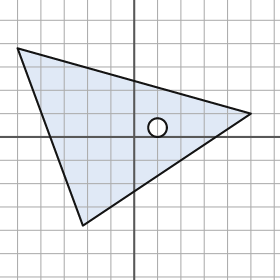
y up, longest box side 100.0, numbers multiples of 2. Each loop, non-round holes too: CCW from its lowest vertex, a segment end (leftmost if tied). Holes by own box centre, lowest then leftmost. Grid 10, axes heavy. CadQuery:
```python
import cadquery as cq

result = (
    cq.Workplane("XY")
    .moveTo(-22.0, -38.0)
    .lineTo(50.0, 10.0)
    .lineTo(-50.0, 38.0)
    .close()
    .moveTo(10.0, 4.0)
    .circle(4.0)
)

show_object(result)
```